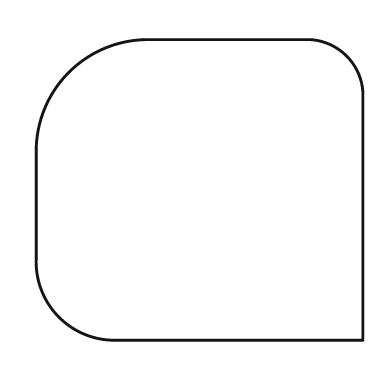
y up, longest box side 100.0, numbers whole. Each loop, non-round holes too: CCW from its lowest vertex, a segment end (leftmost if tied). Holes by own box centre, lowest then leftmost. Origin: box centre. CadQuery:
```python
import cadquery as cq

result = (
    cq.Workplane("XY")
    .moveTo(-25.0, -46.0)
    .lineTo(50.0, -46.0)
    .lineTo(50.0, 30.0)
    .threePointArc((45.0, 41.0), (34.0, 46.0))
    .lineTo(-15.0, 46.0)
    .threePointArc((-40.0, 36.0), (-50.0, 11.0))
    .lineTo(-50.0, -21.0)
    .threePointArc((-43.0, -39.0), (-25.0, -46.0))
    .close()
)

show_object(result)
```